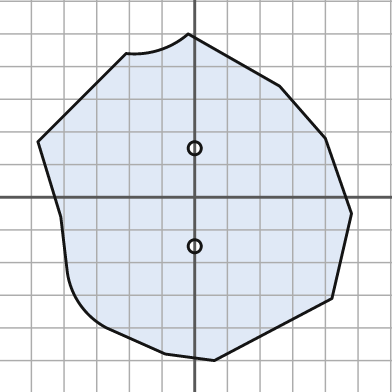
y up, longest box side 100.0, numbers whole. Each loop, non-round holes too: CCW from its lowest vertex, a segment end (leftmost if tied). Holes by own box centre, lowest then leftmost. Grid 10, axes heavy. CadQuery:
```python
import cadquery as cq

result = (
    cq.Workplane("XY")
    .moveTo(6.0, -50.0)
    .lineTo(42.0, -31.0)
    .lineTo(48.0, -5.0)
    .lineTo(40.0, 18.0)
    .lineTo(26.0, 34.0)
    .lineTo(-2.0, 50.0)
    .threePointArc((-11.0, 45.0), (-21.0, 44.0))
    .lineTo(-48.0, 17.0)
    .lineTo(-41.0, -6.0)
    .lineTo(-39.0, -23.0)
    .threePointArc((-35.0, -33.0), (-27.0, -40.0))
    .lineTo(-9.0, -48.0)
    .close()
    .moveTo(0.0, -15.0)
    .circle(2.0)
    .moveTo(0.0, 15.0)
    .circle(2.0)
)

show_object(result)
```